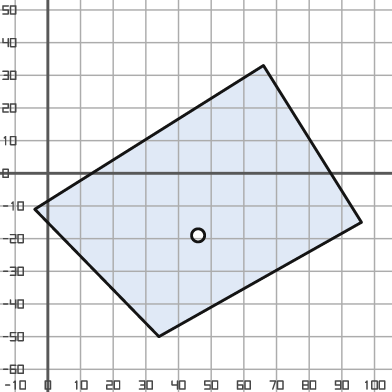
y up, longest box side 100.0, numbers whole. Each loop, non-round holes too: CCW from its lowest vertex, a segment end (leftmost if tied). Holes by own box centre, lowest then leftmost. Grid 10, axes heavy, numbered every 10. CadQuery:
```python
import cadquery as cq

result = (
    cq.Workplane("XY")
    .moveTo(34.0, -50.0)
    .lineTo(96.0, -15.0)
    .lineTo(66.0, 33.0)
    .lineTo(-4.0, -11.0)
    .close()
    .moveTo(46.0, -19.0)
    .circle(2.0)
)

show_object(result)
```